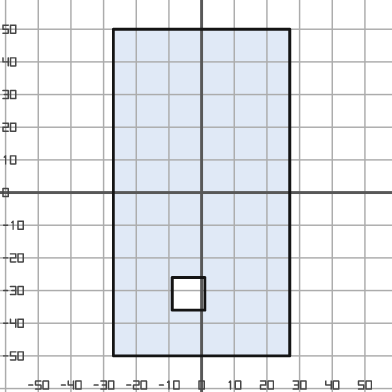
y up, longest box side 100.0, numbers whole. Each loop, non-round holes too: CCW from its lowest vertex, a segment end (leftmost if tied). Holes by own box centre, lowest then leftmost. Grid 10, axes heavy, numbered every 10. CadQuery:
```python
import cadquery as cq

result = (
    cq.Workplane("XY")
    .moveTo(-27.0, -50.0)
    .lineTo(27.0, -50.0)
    .lineTo(27.0, 50.0)
    .lineTo(-27.0, 50.0)
    .close()
    .moveTo(-9.0, -36.0)
    .lineTo(1.0, -36.0)
    .lineTo(1.0, -26.0)
    .lineTo(-9.0, -26.0)
    .close()
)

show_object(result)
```